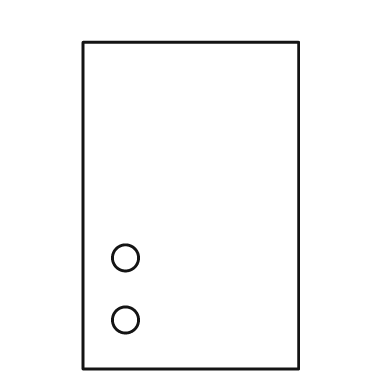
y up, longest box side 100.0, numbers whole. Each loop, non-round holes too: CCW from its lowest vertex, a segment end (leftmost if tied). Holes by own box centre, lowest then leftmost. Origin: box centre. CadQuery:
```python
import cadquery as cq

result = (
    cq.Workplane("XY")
    .moveTo(-33.0, -50.0)
    .lineTo(33.0, -50.0)
    .lineTo(33.0, 50.0)
    .lineTo(-33.0, 50.0)
    .close()
    .moveTo(-20.0, -35.0)
    .circle(4.0)
    .moveTo(-20.0, -16.0)
    .circle(4.0)
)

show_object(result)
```